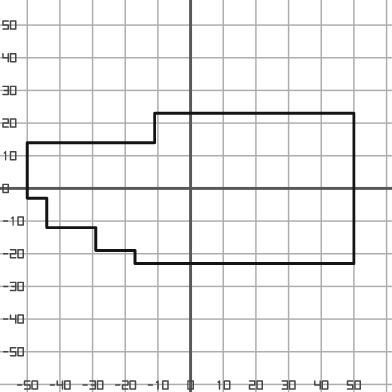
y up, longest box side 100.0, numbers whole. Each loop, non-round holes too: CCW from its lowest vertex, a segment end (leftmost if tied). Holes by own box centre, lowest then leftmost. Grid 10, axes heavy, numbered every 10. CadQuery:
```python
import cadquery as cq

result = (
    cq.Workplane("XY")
    .moveTo(-17.0, -23.0)
    .lineTo(50.0, -23.0)
    .lineTo(50.0, 23.0)
    .lineTo(-11.0, 23.0)
    .lineTo(-11.0, 14.0)
    .lineTo(-50.0, 14.0)
    .lineTo(-50.0, -3.0)
    .lineTo(-44.0, -3.0)
    .lineTo(-44.0, -12.0)
    .lineTo(-29.0, -12.0)
    .lineTo(-29.0, -19.0)
    .lineTo(-17.0, -19.0)
    .close()
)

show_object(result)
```